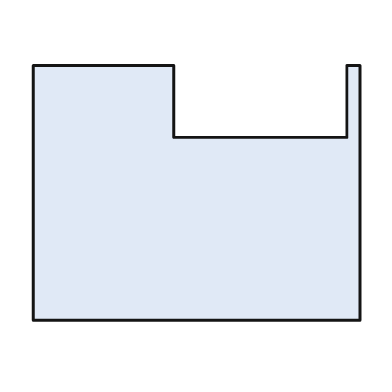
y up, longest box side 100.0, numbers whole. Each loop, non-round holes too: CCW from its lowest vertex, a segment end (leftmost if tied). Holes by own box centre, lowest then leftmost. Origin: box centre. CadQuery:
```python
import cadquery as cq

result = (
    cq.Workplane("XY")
    .moveTo(-50.0, -39.0)
    .lineTo(50.0, -39.0)
    .lineTo(50.0, 39.0)
    .lineTo(46.0, 39.0)
    .lineTo(46.0, 17.0)
    .lineTo(-7.0, 17.0)
    .lineTo(-7.0, 39.0)
    .lineTo(-50.0, 39.0)
    .close()
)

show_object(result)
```